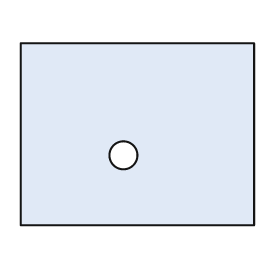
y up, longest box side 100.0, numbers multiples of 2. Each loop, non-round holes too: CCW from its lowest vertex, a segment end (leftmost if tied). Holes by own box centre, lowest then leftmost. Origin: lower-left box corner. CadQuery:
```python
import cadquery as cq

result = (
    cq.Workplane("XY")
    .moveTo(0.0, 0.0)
    .lineTo(100.0, 0.0)
    .lineTo(100.0, 78.0)
    .lineTo(0.0, 78.0)
    .close()
    .moveTo(44.0, 30.0)
    .circle(6.0)
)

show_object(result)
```